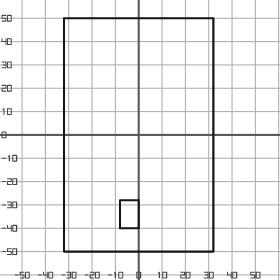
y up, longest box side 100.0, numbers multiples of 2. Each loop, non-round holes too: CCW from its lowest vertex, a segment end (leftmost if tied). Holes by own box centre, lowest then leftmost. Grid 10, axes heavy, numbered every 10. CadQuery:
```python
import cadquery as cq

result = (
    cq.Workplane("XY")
    .moveTo(-32.0, -50.0)
    .lineTo(32.0, -50.0)
    .lineTo(32.0, 50.0)
    .lineTo(-32.0, 50.0)
    .close()
    .moveTo(-8.0, -40.0)
    .lineTo(0.0, -40.0)
    .lineTo(0.0, -28.0)
    .lineTo(-8.0, -28.0)
    .close()
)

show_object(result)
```